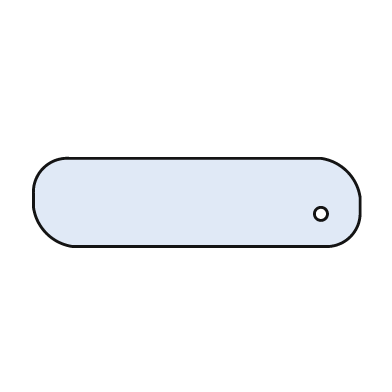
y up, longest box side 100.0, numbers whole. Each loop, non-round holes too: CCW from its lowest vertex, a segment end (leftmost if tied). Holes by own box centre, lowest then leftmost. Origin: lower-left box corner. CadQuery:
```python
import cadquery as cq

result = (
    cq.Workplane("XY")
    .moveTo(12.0, 0.0)
    .lineTo(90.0, 0.0)
    .threePointArc((97.0, 3.0), (100.0, 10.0))
    .lineTo(100.0, 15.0)
    .threePointArc((96.0, 23.0), (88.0, 27.0))
    .lineTo(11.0, 27.0)
    .threePointArc((3.0, 24.0), (0.0, 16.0))
    .lineTo(0.0, 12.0)
    .threePointArc((4.0, 4.0), (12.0, 0.0))
    .close()
    .moveTo(88.0, 10.0)
    .circle(2.0)
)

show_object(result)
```